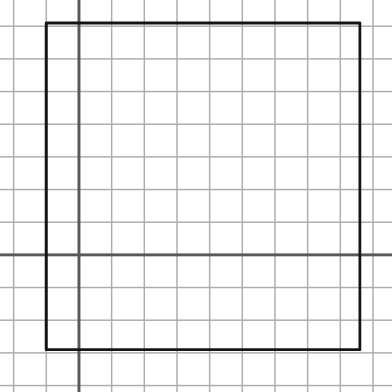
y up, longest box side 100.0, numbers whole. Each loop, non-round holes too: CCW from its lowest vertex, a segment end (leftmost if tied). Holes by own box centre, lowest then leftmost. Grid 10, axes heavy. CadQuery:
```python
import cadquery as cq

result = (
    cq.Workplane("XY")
    .moveTo(-10.0, -29.0)
    .lineTo(86.0, -29.0)
    .lineTo(86.0, 71.0)
    .lineTo(-10.0, 71.0)
    .close()
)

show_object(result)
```